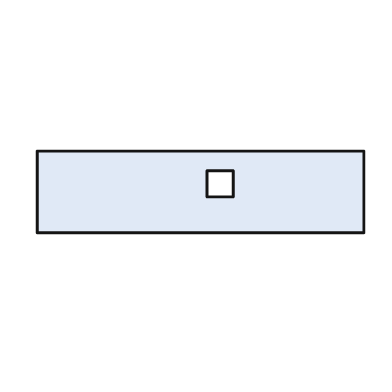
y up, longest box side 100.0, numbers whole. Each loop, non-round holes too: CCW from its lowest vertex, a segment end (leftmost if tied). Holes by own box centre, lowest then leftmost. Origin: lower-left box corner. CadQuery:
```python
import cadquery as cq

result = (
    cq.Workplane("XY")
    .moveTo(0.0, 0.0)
    .lineTo(100.0, 0.0)
    .lineTo(100.0, 25.0)
    .lineTo(0.0, 25.0)
    .close()
    .moveTo(52.0, 11.0)
    .lineTo(60.0, 11.0)
    .lineTo(60.0, 19.0)
    .lineTo(52.0, 19.0)
    .close()
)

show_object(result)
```